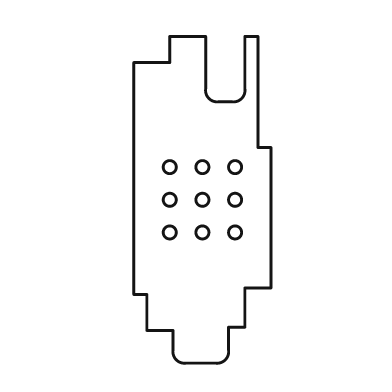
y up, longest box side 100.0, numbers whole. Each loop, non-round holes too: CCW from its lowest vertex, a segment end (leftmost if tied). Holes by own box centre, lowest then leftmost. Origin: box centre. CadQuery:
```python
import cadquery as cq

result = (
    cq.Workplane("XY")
    .moveTo(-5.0, -50.0)
    .lineTo(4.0, -50.0)
    .threePointArc((7.0, -49.0), (8.0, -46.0))
    .lineTo(8.0, -39.0)
    .lineTo(13.0, -39.0)
    .lineTo(13.0, -27.0)
    .lineTo(21.0, -27.0)
    .lineTo(21.0, 16.0)
    .lineTo(17.0, 16.0)
    .lineTo(17.0, 50.0)
    .lineTo(13.0, 50.0)
    .lineTo(13.0, 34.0)
    .threePointArc((12.0, 31.0), (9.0, 30.0))
    .lineTo(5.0, 30.0)
    .threePointArc((2.0, 31.0), (1.0, 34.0))
    .lineTo(1.0, 50.0)
    .lineTo(-10.0, 50.0)
    .lineTo(-10.0, 42.0)
    .lineTo(-21.0, 42.0)
    .lineTo(-21.0, -29.0)
    .lineTo(-17.0, -29.0)
    .lineTo(-17.0, -40.0)
    .lineTo(-9.0, -40.0)
    .lineTo(-9.0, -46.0)
    .threePointArc((-8.0, -49.0), (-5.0, -50.0))
    .close()
    .moveTo(-10.0, -10.0)
    .circle(2.0)
    .moveTo(0.0, -10.0)
    .circle(2.0)
    .moveTo(10.0, -10.0)
    .circle(2.0)
    .moveTo(-10.0, 0.0)
    .circle(2.0)
    .moveTo(0.0, 0.0)
    .circle(2.0)
    .moveTo(10.0, 0.0)
    .circle(2.0)
    .moveTo(-10.0, 10.0)
    .circle(2.0)
    .moveTo(0.0, 10.0)
    .circle(2.0)
    .moveTo(10.0, 10.0)
    .circle(2.0)
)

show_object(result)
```